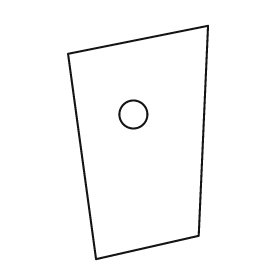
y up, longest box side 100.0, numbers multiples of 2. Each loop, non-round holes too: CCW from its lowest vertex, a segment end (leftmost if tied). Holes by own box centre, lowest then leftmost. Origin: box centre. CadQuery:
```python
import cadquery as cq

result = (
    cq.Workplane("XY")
    .moveTo(-18.0, -50.0)
    .lineTo(26.0, -40.0)
    .lineTo(30.0, 50.0)
    .lineTo(-30.0, 38.0)
    .close()
    .moveTo(-2.0, 12.0)
    .circle(6.0)
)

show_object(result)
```